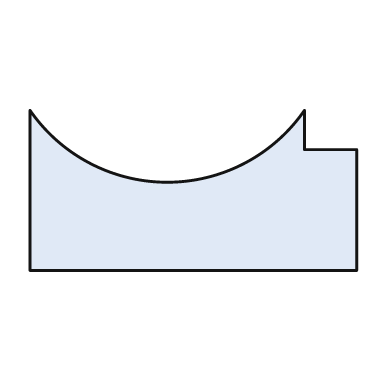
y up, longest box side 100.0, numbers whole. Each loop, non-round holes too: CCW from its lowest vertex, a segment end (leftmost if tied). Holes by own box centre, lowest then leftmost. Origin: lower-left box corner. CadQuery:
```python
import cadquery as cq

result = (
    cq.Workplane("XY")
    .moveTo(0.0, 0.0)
    .lineTo(100.0, 0.0)
    .lineTo(100.0, 37.0)
    .lineTo(84.0, 37.0)
    .lineTo(84.0, 49.0)
    .threePointArc((42.0, 27.0), (0.0, 49.0))
    .close()
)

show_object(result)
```